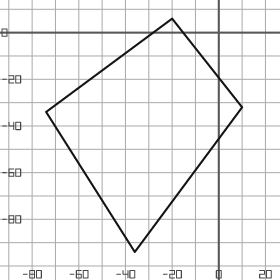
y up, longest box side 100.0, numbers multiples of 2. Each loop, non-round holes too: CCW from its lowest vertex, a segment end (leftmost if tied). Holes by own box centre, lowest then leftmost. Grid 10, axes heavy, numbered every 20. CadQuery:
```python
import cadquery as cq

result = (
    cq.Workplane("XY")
    .moveTo(-36.0, -94.0)
    .lineTo(10.0, -32.0)
    .lineTo(-20.0, 6.0)
    .lineTo(-74.0, -34.0)
    .close()
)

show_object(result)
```